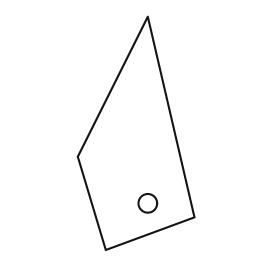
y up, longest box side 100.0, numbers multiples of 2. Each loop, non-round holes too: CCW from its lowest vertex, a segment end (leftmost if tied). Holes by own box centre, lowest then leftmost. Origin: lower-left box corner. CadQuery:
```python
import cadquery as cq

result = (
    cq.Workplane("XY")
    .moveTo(12.0, 0.0)
    .lineTo(50.0, 14.0)
    .lineTo(30.0, 100.0)
    .lineTo(0.0, 40.0)
    .close()
    .moveTo(30.0, 20.0)
    .circle(4.0)
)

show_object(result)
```